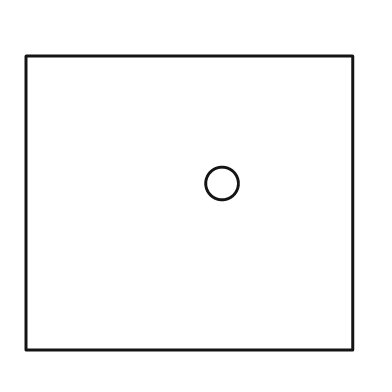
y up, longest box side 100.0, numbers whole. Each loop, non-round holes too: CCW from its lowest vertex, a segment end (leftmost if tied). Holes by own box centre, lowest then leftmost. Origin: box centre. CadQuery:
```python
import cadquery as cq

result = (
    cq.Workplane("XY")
    .moveTo(-50.0, -45.0)
    .lineTo(50.0, -45.0)
    .lineTo(50.0, 45.0)
    .lineTo(-50.0, 45.0)
    .close()
    .moveTo(10.0, 6.0)
    .circle(5.0)
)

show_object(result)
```